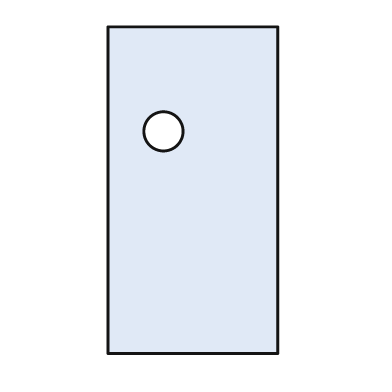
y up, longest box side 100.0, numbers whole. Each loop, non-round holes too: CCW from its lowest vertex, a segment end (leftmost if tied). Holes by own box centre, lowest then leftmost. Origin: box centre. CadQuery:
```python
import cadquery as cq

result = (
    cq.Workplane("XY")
    .moveTo(-26.0, -50.0)
    .lineTo(26.0, -50.0)
    .lineTo(26.0, 50.0)
    .lineTo(-26.0, 50.0)
    .close()
    .moveTo(-9.0, 18.0)
    .circle(6.0)
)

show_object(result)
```